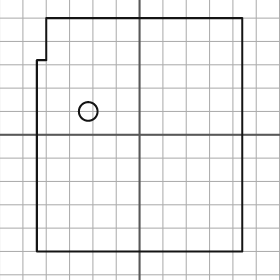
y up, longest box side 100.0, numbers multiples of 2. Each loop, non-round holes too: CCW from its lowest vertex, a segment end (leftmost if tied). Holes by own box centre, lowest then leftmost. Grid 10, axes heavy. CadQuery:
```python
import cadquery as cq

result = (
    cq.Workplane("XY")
    .moveTo(-44.0, -50.0)
    .lineTo(44.0, -50.0)
    .lineTo(44.0, 50.0)
    .lineTo(-40.0, 50.0)
    .lineTo(-40.0, 32.0)
    .lineTo(-44.0, 32.0)
    .close()
    .moveTo(-22.0, 10.0)
    .circle(4.0)
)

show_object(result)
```